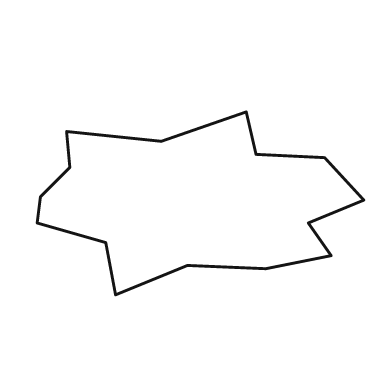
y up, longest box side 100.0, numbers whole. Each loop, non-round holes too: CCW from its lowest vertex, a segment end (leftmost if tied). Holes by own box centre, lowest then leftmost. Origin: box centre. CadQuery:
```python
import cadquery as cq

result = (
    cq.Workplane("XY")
    .moveTo(-26.0, -28.0)
    .lineTo(-4.0, -19.0)
    .lineTo(20.0, -20.0)
    .lineTo(40.0, -16.0)
    .lineTo(33.0, -6.0)
    .lineTo(50.0, 1.0)
    .lineTo(38.0, 14.0)
    .lineTo(17.0, 15.0)
    .lineTo(14.0, 28.0)
    .lineTo(-12.0, 19.0)
    .lineTo(-41.0, 22.0)
    .lineTo(-40.0, 11.0)
    .lineTo(-49.0, 2.0)
    .lineTo(-50.0, -6.0)
    .lineTo(-29.0, -12.0)
    .close()
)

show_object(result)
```